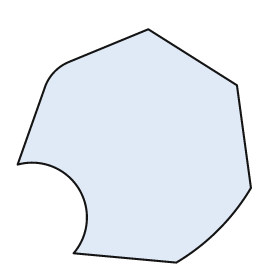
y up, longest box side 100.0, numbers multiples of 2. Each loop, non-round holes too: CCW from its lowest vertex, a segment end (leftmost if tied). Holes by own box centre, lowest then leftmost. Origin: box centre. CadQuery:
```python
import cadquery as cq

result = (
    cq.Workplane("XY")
    .moveTo(18.0, -50.0)
    .threePointArc((36.0, -36.0), (50.0, -18.0))
    .lineTo(44.0, 26.0)
    .lineTo(6.0, 50.0)
    .lineTo(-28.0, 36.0)
    .threePointArc((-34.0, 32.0), (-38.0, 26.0))
    .lineTo(-50.0, -8.0)
    .threePointArc((-24.0, -18.0), (-26.0, -46.0))
    .close()
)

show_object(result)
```